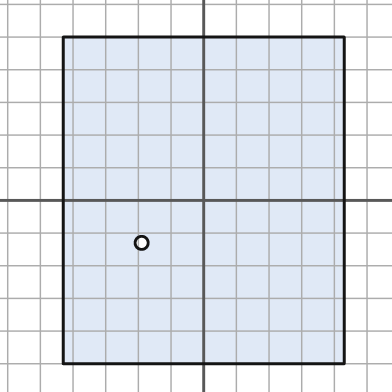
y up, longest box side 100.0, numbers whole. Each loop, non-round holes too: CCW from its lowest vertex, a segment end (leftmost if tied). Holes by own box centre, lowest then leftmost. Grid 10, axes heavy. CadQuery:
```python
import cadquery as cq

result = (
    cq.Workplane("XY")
    .moveTo(-43.0, -50.0)
    .lineTo(43.0, -50.0)
    .lineTo(43.0, 50.0)
    .lineTo(-43.0, 50.0)
    .close()
    .moveTo(-19.0, -13.0)
    .circle(2.0)
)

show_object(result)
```